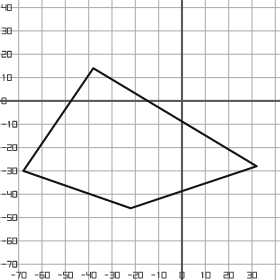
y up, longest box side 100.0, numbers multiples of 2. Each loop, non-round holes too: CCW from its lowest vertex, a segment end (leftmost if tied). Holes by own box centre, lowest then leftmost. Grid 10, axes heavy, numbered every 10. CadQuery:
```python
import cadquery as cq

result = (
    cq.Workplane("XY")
    .moveTo(-22.0, -46.0)
    .lineTo(32.0, -28.0)
    .lineTo(-38.0, 14.0)
    .lineTo(-68.0, -30.0)
    .close()
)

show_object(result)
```